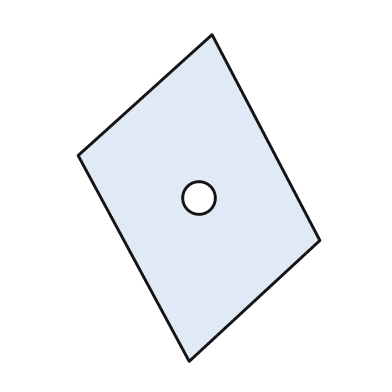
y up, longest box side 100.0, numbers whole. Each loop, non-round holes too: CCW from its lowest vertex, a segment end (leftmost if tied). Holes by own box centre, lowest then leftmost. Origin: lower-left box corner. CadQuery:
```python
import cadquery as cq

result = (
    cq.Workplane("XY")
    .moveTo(34.0, 0.0)
    .lineTo(74.0, 37.0)
    .lineTo(41.0, 100.0)
    .lineTo(0.0, 63.0)
    .close()
    .moveTo(37.0, 50.0)
    .circle(5.0)
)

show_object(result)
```